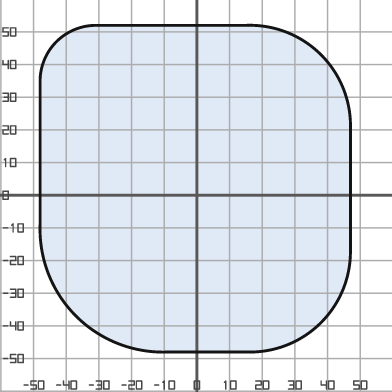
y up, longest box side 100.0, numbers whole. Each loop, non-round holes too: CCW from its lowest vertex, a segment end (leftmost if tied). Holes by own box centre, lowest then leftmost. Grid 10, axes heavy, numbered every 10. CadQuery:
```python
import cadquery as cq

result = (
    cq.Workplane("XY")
    .moveTo(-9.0, -48.0)
    .lineTo(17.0, -48.0)
    .threePointArc((38.0, -39.0), (47.0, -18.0))
    .lineTo(47.0, 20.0)
    .threePointArc((38.0, 43.0), (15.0, 52.0))
    .lineTo(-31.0, 52.0)
    .threePointArc((-43.0, 47.0), (-48.0, 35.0))
    .lineTo(-48.0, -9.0)
    .threePointArc((-37.0, -37.0), (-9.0, -48.0))
    .close()
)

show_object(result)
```